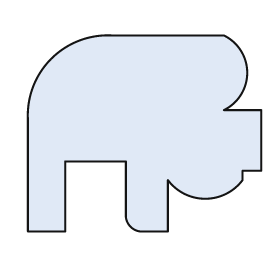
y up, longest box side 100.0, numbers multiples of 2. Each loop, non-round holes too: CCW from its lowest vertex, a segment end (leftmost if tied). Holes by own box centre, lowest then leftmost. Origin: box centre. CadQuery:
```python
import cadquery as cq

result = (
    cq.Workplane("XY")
    .moveTo(-50.0, -42.0)
    .lineTo(-34.0, -42.0)
    .lineTo(-34.0, -12.0)
    .lineTo(-8.0, -12.0)
    .lineTo(-8.0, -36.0)
    .threePointArc((-6.0, -40.0), (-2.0, -42.0))
    .lineTo(10.0, -42.0)
    .lineTo(10.0, -20.0)
    .threePointArc((26.0, -28.0), (42.0, -20.0))
    .lineTo(42.0, -16.0)
    .lineTo(50.0, -16.0)
    .lineTo(50.0, 10.0)
    .lineTo(34.0, 10.0)
    .threePointArc((44.0, 26.0), (34.0, 42.0))
    .lineTo(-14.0, 42.0)
    .threePointArc((-40.0, 32.0), (-50.0, 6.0))
    .close()
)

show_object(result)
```